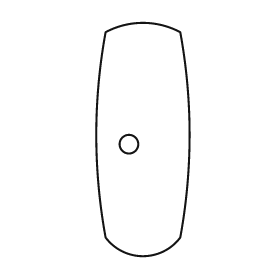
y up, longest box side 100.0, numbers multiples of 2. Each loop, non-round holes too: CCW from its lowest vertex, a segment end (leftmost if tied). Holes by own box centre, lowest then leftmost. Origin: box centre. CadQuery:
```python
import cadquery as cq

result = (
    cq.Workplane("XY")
    .moveTo(-16.0, -42.0)
    .threePointArc((0.0, -50.0), (16.0, -42.0))
    .threePointArc((20.0, 2.0), (16.0, 46.0))
    .threePointArc((0.0, 50.0), (-16.0, 46.0))
    .threePointArc((-20.0, 2.0), (-16.0, -42.0))
    .close()
    .moveTo(-6.0, -2.0)
    .circle(4.0)
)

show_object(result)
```